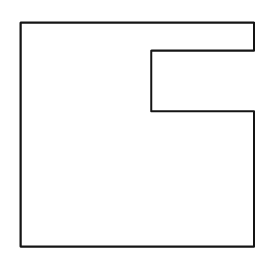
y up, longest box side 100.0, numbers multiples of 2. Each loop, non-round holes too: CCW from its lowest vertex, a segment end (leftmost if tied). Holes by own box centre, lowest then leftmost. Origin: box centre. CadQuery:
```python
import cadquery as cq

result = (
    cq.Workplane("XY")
    .moveTo(-50.0, -48.0)
    .lineTo(50.0, -48.0)
    .lineTo(50.0, 10.0)
    .lineTo(6.0, 10.0)
    .lineTo(6.0, 36.0)
    .lineTo(50.0, 36.0)
    .lineTo(50.0, 48.0)
    .lineTo(-50.0, 48.0)
    .close()
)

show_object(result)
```